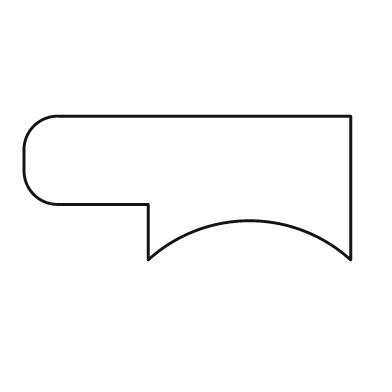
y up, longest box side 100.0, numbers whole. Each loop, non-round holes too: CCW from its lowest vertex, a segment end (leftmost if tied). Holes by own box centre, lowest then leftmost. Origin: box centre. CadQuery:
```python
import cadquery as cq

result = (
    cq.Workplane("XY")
    .moveTo(-12.0, -22.0)
    .threePointArc((19.0, -10.0), (50.0, -22.0))
    .lineTo(50.0, 22.0)
    .lineTo(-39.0, 22.0)
    .threePointArc((-47.0, 19.0), (-50.0, 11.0))
    .lineTo(-50.0, 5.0)
    .threePointArc((-47.0, -2.0), (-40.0, -5.0))
    .lineTo(-12.0, -5.0)
    .close()
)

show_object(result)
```